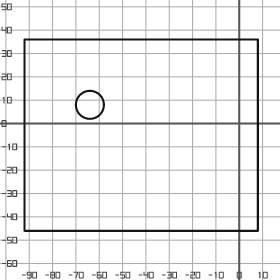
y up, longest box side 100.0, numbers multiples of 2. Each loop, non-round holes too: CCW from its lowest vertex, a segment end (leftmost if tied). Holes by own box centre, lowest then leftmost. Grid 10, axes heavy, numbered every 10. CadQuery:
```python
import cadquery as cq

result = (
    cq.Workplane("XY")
    .moveTo(-92.0, -46.0)
    .lineTo(8.0, -46.0)
    .lineTo(8.0, 36.0)
    .lineTo(-92.0, 36.0)
    .close()
    .moveTo(-64.0, 8.0)
    .circle(6.0)
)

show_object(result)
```